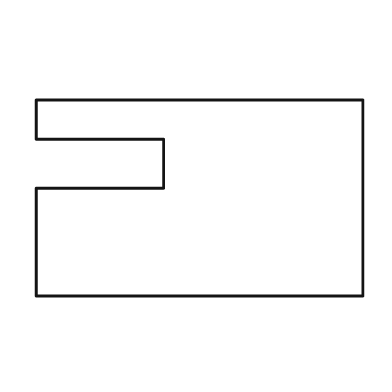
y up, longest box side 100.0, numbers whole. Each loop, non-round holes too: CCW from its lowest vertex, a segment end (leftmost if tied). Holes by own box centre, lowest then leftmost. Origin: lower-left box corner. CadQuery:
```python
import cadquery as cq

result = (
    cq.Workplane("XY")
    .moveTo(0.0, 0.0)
    .lineTo(100.0, 0.0)
    .lineTo(100.0, 60.0)
    .lineTo(0.0, 60.0)
    .lineTo(0.0, 48.0)
    .lineTo(39.0, 48.0)
    .lineTo(39.0, 33.0)
    .lineTo(0.0, 33.0)
    .close()
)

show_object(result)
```